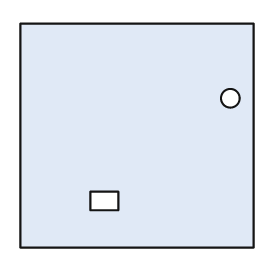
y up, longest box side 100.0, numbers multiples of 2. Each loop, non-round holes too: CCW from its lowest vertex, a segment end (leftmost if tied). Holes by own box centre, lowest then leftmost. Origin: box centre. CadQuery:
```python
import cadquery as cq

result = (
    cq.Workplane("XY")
    .moveTo(-50.0, -48.0)
    .lineTo(50.0, -48.0)
    .lineTo(50.0, 48.0)
    .lineTo(-50.0, 48.0)
    .close()
    .moveTo(-20.0, -32.0)
    .lineTo(-8.0, -32.0)
    .lineTo(-8.0, -24.0)
    .lineTo(-20.0, -24.0)
    .close()
    .moveTo(40.0, 16.0)
    .circle(4.0)
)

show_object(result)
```